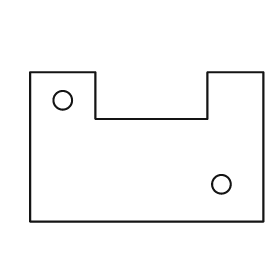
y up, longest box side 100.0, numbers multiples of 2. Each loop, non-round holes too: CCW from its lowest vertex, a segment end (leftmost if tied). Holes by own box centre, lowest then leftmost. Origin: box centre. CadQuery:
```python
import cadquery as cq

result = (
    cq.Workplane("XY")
    .moveTo(-50.0, -32.0)
    .lineTo(50.0, -32.0)
    .lineTo(50.0, 32.0)
    .lineTo(26.0, 32.0)
    .lineTo(26.0, 12.0)
    .lineTo(-22.0, 12.0)
    .lineTo(-22.0, 32.0)
    .lineTo(-50.0, 32.0)
    .close()
    .moveTo(32.0, -16.0)
    .circle(4.0)
    .moveTo(-36.0, 20.0)
    .circle(4.0)
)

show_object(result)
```